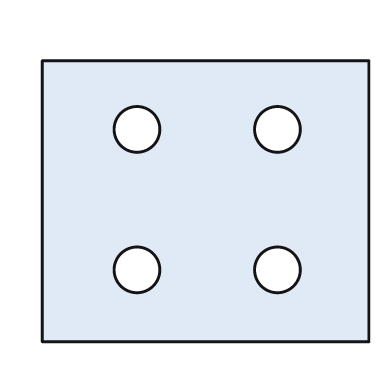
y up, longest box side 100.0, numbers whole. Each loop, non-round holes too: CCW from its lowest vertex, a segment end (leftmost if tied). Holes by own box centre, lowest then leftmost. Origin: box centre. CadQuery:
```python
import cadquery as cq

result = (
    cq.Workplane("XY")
    .moveTo(-50.0, -43.0)
    .lineTo(50.0, -43.0)
    .lineTo(50.0, 43.0)
    .lineTo(-50.0, 43.0)
    .close()
    .moveTo(-21.0, -21.0)
    .circle(7.0)
    .moveTo(22.0, -21.0)
    .circle(7.0)
    .moveTo(-21.0, 22.0)
    .circle(7.0)
    .moveTo(22.0, 22.0)
    .circle(7.0)
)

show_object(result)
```